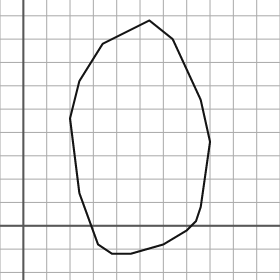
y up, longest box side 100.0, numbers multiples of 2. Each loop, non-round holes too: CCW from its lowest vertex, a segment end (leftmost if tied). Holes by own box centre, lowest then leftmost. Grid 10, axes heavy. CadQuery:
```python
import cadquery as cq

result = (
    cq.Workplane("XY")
    .moveTo(38.0, -12.0)
    .lineTo(46.0, -12.0)
    .lineTo(60.0, -8.0)
    .lineTo(70.0, -2.0)
    .lineTo(74.0, 2.0)
    .lineTo(76.0, 8.0)
    .lineTo(80.0, 36.0)
    .lineTo(76.0, 54.0)
    .lineTo(64.0, 80.0)
    .lineTo(54.0, 88.0)
    .lineTo(34.0, 78.0)
    .lineTo(24.0, 62.0)
    .lineTo(20.0, 46.0)
    .lineTo(24.0, 14.0)
    .lineTo(32.0, -8.0)
    .close()
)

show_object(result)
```